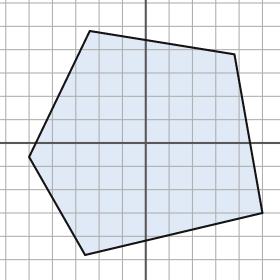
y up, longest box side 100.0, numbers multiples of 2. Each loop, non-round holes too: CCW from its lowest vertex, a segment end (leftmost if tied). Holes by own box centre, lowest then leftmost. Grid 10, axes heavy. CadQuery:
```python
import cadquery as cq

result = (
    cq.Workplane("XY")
    .moveTo(-26.0, -48.0)
    .lineTo(50.0, -30.0)
    .lineTo(38.0, 38.0)
    .lineTo(-24.0, 48.0)
    .lineTo(-50.0, -6.0)
    .close()
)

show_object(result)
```